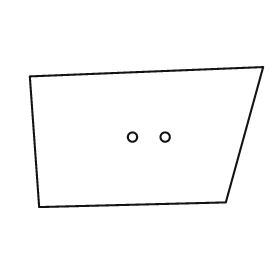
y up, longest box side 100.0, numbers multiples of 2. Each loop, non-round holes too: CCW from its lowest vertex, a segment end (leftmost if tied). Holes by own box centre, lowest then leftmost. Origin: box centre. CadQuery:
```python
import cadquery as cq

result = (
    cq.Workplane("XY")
    .moveTo(-46.0, -30.0)
    .lineTo(34.0, -28.0)
    .lineTo(50.0, 30.0)
    .lineTo(-50.0, 26.0)
    .close()
    .moveTo(-6.0, 0.0)
    .circle(2.0)
    .moveTo(8.0, 0.0)
    .circle(2.0)
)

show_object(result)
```